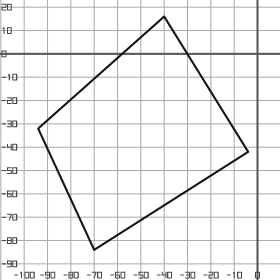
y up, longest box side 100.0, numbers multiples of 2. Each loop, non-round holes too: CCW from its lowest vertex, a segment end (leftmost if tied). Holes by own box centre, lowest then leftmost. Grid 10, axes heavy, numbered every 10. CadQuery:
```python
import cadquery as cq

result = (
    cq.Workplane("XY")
    .moveTo(-70.0, -84.0)
    .lineTo(-4.0, -42.0)
    .lineTo(-40.0, 16.0)
    .lineTo(-94.0, -32.0)
    .close()
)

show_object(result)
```